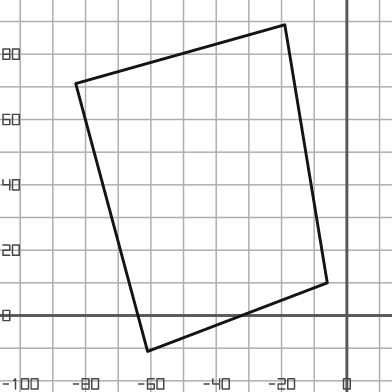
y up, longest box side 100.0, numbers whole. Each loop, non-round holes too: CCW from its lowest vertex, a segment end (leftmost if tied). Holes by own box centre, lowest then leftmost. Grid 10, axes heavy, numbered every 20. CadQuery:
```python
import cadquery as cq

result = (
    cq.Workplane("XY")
    .moveTo(-61.0, -11.0)
    .lineTo(-6.0, 10.0)
    .lineTo(-19.0, 89.0)
    .lineTo(-83.0, 71.0)
    .close()
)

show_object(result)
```